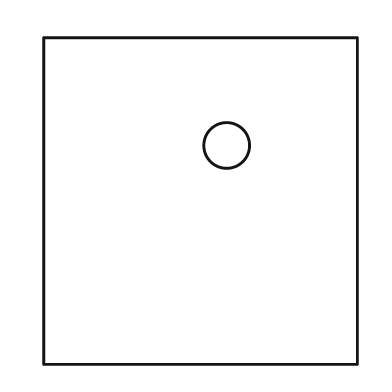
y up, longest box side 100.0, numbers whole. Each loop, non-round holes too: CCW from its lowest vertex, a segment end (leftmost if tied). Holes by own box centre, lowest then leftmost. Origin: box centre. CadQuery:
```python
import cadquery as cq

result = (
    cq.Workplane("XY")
    .moveTo(-48.0, -50.0)
    .lineTo(48.0, -50.0)
    .lineTo(48.0, 50.0)
    .lineTo(-48.0, 50.0)
    .close()
    .moveTo(8.0, 17.0)
    .circle(7.0)
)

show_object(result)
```